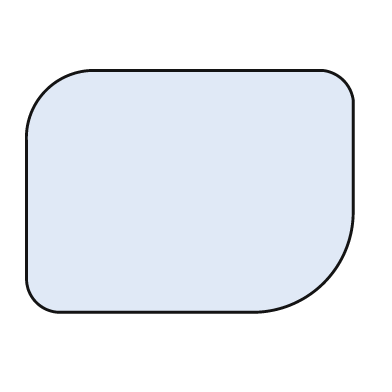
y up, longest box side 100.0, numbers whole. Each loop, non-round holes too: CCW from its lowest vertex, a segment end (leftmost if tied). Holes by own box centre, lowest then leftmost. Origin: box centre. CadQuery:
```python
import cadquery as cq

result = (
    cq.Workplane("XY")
    .moveTo(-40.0, -37.0)
    .lineTo(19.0, -37.0)
    .threePointArc((41.0, -28.0), (50.0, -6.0))
    .lineTo(50.0, 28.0)
    .threePointArc((47.0, 34.0), (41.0, 37.0))
    .lineTo(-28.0, 37.0)
    .threePointArc((-44.0, 31.0), (-50.0, 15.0))
    .lineTo(-50.0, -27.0)
    .threePointArc((-47.0, -34.0), (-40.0, -37.0))
    .close()
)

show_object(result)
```